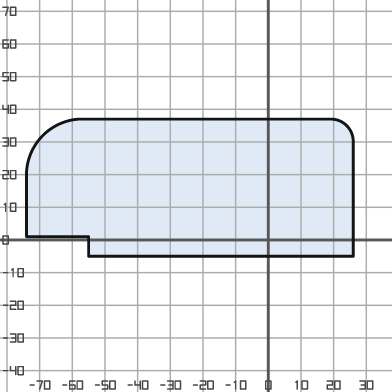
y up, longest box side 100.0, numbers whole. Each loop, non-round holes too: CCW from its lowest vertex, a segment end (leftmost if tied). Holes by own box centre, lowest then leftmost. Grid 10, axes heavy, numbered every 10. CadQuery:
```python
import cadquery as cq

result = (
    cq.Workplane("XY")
    .moveTo(-55.0, -5.0)
    .lineTo(26.0, -5.0)
    .lineTo(26.0, 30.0)
    .threePointArc((24.0, 35.0), (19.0, 37.0))
    .lineTo(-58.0, 37.0)
    .threePointArc((-69.0, 32.0), (-74.0, 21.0))
    .lineTo(-74.0, 1.0)
    .lineTo(-55.0, 1.0)
    .close()
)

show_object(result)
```